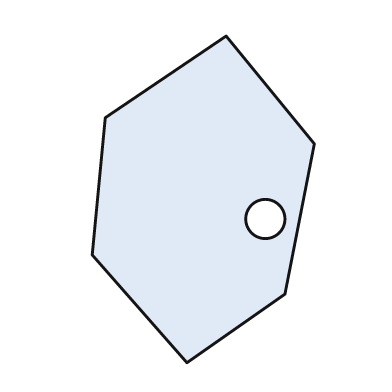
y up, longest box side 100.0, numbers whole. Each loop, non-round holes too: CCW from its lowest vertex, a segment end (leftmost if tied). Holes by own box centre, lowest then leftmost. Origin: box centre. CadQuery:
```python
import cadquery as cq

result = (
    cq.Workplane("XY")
    .moveTo(-5.0, -50.0)
    .lineTo(25.0, -29.0)
    .lineTo(34.0, 17.0)
    .lineTo(7.0, 50.0)
    .lineTo(-30.0, 25.0)
    .lineTo(-34.0, -17.0)
    .close()
    .moveTo(19.0, -6.0)
    .circle(6.0)
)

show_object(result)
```